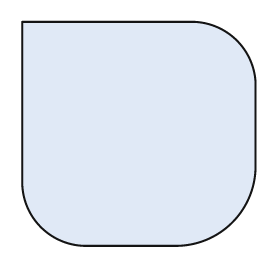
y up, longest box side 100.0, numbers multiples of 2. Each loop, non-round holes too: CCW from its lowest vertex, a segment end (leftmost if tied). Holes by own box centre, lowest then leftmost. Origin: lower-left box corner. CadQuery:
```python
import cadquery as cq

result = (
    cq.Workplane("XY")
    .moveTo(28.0, 0.0)
    .lineTo(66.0, 0.0)
    .threePointArc((90.0, 10.0), (100.0, 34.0))
    .lineTo(100.0, 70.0)
    .threePointArc((92.0, 88.0), (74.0, 96.0))
    .lineTo(0.0, 96.0)
    .lineTo(0.0, 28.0)
    .threePointArc((8.0, 8.0), (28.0, 0.0))
    .close()
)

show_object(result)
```